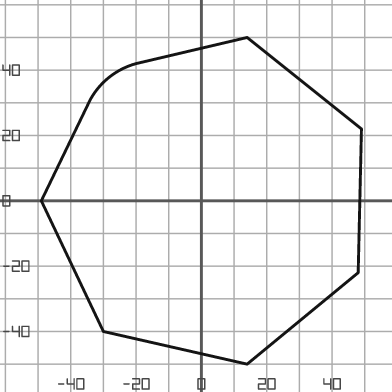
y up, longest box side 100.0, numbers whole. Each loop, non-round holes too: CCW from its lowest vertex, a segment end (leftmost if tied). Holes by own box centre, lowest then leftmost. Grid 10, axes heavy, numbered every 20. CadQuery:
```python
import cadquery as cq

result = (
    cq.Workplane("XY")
    .moveTo(14.0, -50.0)
    .lineTo(48.0, -22.0)
    .lineTo(49.0, 22.0)
    .lineTo(14.0, 50.0)
    .lineTo(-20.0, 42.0)
    .threePointArc((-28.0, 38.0), (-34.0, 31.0))
    .lineTo(-49.0, 0.0)
    .lineTo(-30.0, -40.0)
    .close()
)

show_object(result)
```